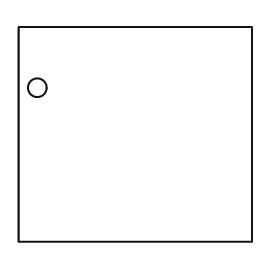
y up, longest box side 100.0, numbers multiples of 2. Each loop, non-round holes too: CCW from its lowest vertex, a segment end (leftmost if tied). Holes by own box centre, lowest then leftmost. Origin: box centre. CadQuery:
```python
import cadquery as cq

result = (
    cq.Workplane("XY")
    .moveTo(-50.0, -46.0)
    .lineTo(50.0, -46.0)
    .lineTo(50.0, 46.0)
    .lineTo(-50.0, 46.0)
    .close()
    .moveTo(-42.0, 20.0)
    .circle(4.0)
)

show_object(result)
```